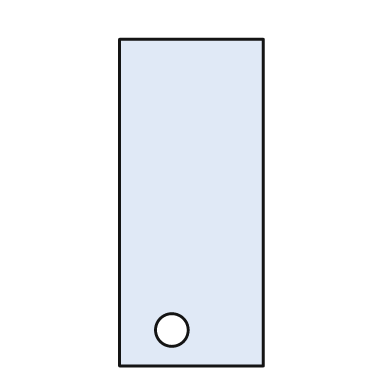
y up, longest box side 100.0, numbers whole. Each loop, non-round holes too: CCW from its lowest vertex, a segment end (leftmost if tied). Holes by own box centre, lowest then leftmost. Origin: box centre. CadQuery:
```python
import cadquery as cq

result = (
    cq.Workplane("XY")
    .moveTo(-22.0, -50.0)
    .lineTo(22.0, -50.0)
    .lineTo(22.0, 50.0)
    .lineTo(-22.0, 50.0)
    .close()
    .moveTo(-6.0, -39.0)
    .circle(5.0)
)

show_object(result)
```